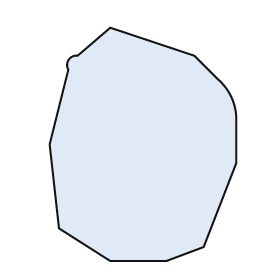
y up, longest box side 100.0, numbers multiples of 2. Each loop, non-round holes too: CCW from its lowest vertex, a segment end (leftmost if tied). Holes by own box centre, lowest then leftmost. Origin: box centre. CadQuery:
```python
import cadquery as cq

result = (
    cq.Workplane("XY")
    .moveTo(-14.0, -50.0)
    .lineTo(10.0, -50.0)
    .lineTo(26.0, -44.0)
    .lineTo(40.0, -8.0)
    .lineTo(40.0, 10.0)
    .threePointArc((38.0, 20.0), (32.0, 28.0))
    .lineTo(22.0, 38.0)
    .lineTo(-14.0, 50.0)
    .lineTo(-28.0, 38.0)
    .threePointArc((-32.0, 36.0), (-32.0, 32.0))
    .lineTo(-40.0, 0.0)
    .lineTo(-36.0, -36.0)
    .close()
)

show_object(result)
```